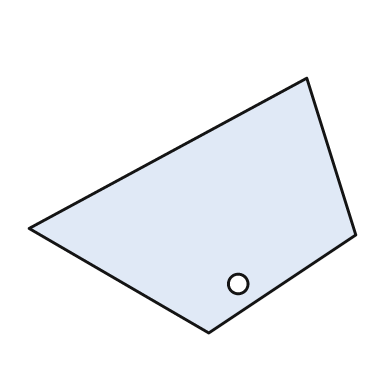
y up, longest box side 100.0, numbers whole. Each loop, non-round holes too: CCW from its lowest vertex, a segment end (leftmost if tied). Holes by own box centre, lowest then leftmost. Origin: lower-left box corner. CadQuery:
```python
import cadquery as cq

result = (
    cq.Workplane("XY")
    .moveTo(55.0, 0.0)
    .lineTo(100.0, 30.0)
    .lineTo(85.0, 78.0)
    .lineTo(0.0, 32.0)
    .close()
    .moveTo(64.0, 15.0)
    .circle(3.0)
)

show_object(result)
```